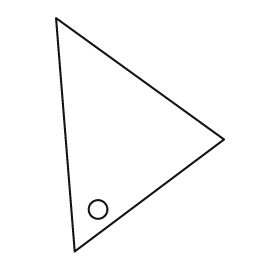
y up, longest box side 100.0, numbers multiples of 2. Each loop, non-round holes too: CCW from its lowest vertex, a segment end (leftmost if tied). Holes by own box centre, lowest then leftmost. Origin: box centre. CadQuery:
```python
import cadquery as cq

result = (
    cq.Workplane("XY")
    .moveTo(-28.0, -50.0)
    .lineTo(36.0, -2.0)
    .lineTo(-36.0, 50.0)
    .close()
    .moveTo(-18.0, -32.0)
    .circle(4.0)
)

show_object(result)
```